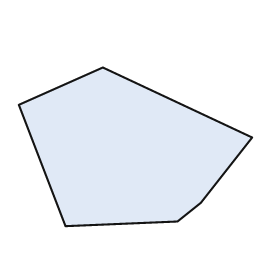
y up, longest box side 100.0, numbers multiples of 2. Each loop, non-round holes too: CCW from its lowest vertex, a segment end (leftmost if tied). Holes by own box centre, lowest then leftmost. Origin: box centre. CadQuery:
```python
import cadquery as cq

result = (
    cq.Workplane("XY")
    .moveTo(-30.0, -34.0)
    .lineTo(18.0, -32.0)
    .lineTo(28.0, -24.0)
    .lineTo(50.0, 4.0)
    .lineTo(-14.0, 34.0)
    .lineTo(-50.0, 18.0)
    .close()
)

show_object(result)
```